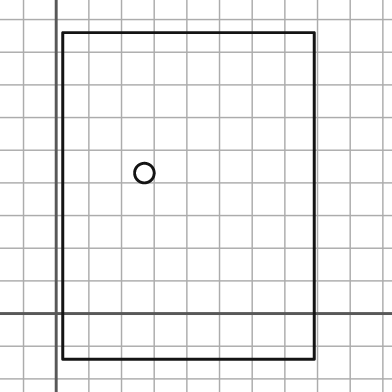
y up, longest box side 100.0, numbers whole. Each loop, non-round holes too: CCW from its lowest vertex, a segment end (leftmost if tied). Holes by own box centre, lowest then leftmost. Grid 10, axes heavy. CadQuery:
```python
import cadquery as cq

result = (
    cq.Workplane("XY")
    .moveTo(2.0, -14.0)
    .lineTo(79.0, -14.0)
    .lineTo(79.0, 86.0)
    .lineTo(2.0, 86.0)
    .close()
    .moveTo(27.0, 43.0)
    .circle(3.0)
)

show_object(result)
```